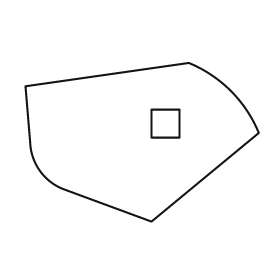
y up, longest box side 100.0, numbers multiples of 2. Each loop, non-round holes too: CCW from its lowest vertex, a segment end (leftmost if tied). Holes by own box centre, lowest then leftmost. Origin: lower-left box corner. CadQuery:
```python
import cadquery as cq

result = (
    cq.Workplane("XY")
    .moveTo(54.0, 0.0)
    .lineTo(100.0, 38.0)
    .threePointArc((88.0, 56.0), (70.0, 68.0))
    .lineTo(0.0, 58.0)
    .lineTo(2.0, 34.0)
    .threePointArc((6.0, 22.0), (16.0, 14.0))
    .close()
    .moveTo(54.0, 36.0)
    .lineTo(66.0, 36.0)
    .lineTo(66.0, 48.0)
    .lineTo(54.0, 48.0)
    .close()
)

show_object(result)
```